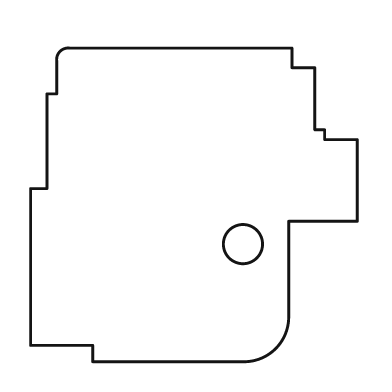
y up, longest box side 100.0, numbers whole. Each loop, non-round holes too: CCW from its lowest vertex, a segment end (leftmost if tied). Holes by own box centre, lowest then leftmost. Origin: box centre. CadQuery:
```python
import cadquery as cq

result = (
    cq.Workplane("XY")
    .moveTo(-31.0, -48.0)
    .lineTo(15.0, -48.0)
    .threePointArc((25.0, -44.0), (29.0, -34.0))
    .lineTo(29.0, -5.0)
    .lineTo(50.0, -5.0)
    .lineTo(50.0, 20.0)
    .lineTo(40.0, 20.0)
    .lineTo(40.0, 23.0)
    .lineTo(37.0, 23.0)
    .lineTo(37.0, 42.0)
    .lineTo(30.0, 42.0)
    .lineTo(30.0, 48.0)
    .lineTo(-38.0, 48.0)
    .threePointArc((-41.0, 47.0), (-42.0, 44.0))
    .lineTo(-42.0, 34.0)
    .lineTo(-45.0, 34.0)
    .lineTo(-45.0, 5.0)
    .lineTo(-50.0, 5.0)
    .lineTo(-50.0, -43.0)
    .lineTo(-31.0, -43.0)
    .close()
    .moveTo(15.0, -12.0)
    .circle(6.0)
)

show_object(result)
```